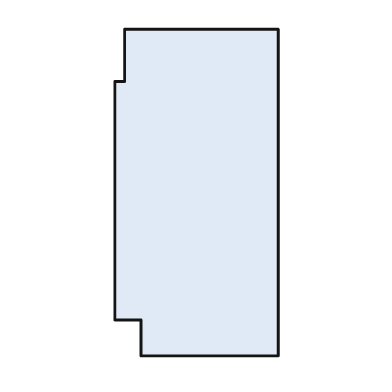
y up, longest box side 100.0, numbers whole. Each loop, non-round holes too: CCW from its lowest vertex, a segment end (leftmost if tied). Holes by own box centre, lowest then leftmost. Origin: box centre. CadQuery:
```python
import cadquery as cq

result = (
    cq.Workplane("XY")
    .moveTo(-17.0, -50.0)
    .lineTo(25.0, -50.0)
    .lineTo(25.0, 50.0)
    .lineTo(-22.0, 50.0)
    .lineTo(-22.0, 34.0)
    .lineTo(-25.0, 34.0)
    .lineTo(-25.0, -39.0)
    .lineTo(-17.0, -39.0)
    .close()
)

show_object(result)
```